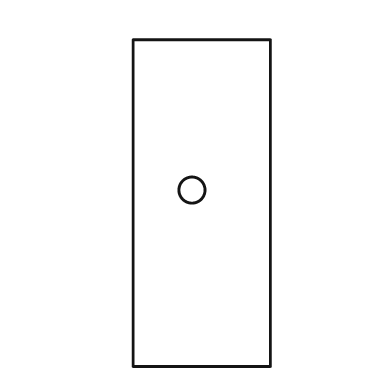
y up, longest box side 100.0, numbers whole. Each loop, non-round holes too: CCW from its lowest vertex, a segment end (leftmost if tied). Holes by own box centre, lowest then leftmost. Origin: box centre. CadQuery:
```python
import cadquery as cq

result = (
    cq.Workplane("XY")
    .moveTo(-21.0, -50.0)
    .lineTo(21.0, -50.0)
    .lineTo(21.0, 50.0)
    .lineTo(-21.0, 50.0)
    .close()
    .moveTo(-3.0, 4.0)
    .circle(4.0)
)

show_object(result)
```